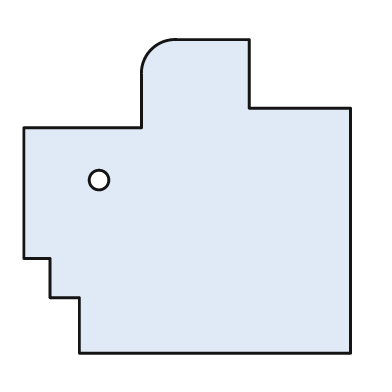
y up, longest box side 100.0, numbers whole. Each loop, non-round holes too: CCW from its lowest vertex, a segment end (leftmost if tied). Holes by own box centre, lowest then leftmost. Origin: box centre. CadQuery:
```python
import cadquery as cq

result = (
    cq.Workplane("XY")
    .moveTo(-33.0, -48.0)
    .lineTo(50.0, -48.0)
    .lineTo(50.0, 27.0)
    .lineTo(19.0, 27.0)
    .lineTo(19.0, 48.0)
    .lineTo(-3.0, 48.0)
    .threePointArc((-11.0, 45.0), (-14.0, 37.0))
    .lineTo(-14.0, 21.0)
    .lineTo(-50.0, 21.0)
    .lineTo(-50.0, -19.0)
    .lineTo(-42.0, -19.0)
    .lineTo(-42.0, -31.0)
    .lineTo(-33.0, -31.0)
    .close()
    .moveTo(-27.0, 5.0)
    .circle(3.0)
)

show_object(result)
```